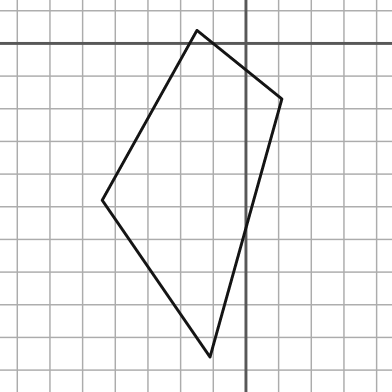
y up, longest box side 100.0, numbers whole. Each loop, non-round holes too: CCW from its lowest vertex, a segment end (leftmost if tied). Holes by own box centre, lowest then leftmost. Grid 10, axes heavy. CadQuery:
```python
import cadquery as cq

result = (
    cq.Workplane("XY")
    .moveTo(-11.0, -96.0)
    .lineTo(11.0, -17.0)
    .lineTo(-15.0, 4.0)
    .lineTo(-44.0, -48.0)
    .close()
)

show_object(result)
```